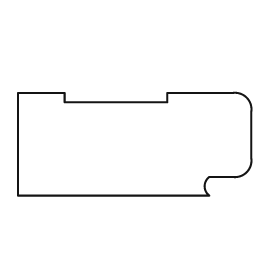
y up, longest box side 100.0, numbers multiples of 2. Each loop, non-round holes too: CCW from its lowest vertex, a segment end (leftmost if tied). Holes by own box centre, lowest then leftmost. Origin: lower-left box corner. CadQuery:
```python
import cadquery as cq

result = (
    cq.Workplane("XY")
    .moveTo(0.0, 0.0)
    .lineTo(82.0, 0.0)
    .threePointArc((80.0, 4.0), (82.0, 8.0))
    .lineTo(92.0, 8.0)
    .threePointArc((98.0, 10.0), (100.0, 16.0))
    .lineTo(100.0, 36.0)
    .threePointArc((98.0, 42.0), (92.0, 44.0))
    .lineTo(64.0, 44.0)
    .lineTo(64.0, 40.0)
    .lineTo(20.0, 40.0)
    .lineTo(20.0, 44.0)
    .lineTo(0.0, 44.0)
    .close()
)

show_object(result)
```